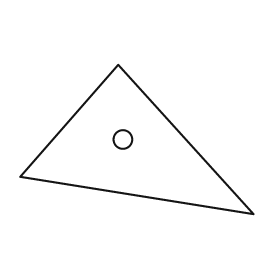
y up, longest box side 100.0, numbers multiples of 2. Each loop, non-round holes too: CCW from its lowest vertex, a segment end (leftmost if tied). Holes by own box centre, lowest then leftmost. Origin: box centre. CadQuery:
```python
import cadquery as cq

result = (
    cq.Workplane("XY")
    .moveTo(50.0, -32.0)
    .lineTo(-8.0, 32.0)
    .lineTo(-50.0, -16.0)
    .close()
    .moveTo(-6.0, 0.0)
    .circle(4.0)
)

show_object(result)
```